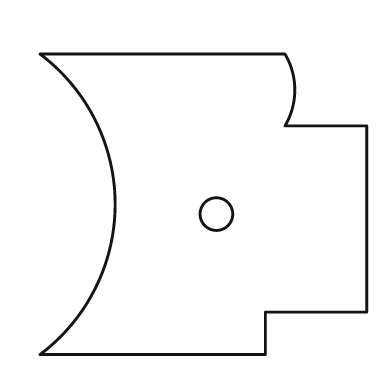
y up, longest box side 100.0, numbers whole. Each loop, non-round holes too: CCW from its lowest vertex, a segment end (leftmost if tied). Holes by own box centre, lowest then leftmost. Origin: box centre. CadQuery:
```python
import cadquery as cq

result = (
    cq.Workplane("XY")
    .moveTo(-50.0, -46.0)
    .lineTo(19.0, -46.0)
    .lineTo(19.0, -33.0)
    .lineTo(50.0, -33.0)
    .lineTo(50.0, 24.0)
    .lineTo(25.0, 24.0)
    .threePointArc((28.0, 35.0), (25.0, 46.0))
    .lineTo(-50.0, 46.0)
    .threePointArc((-27.0, 0.0), (-50.0, -46.0))
    .close()
    .moveTo(4.0, -3.0)
    .circle(5.0)
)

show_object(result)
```